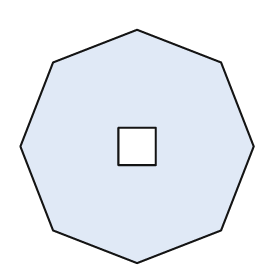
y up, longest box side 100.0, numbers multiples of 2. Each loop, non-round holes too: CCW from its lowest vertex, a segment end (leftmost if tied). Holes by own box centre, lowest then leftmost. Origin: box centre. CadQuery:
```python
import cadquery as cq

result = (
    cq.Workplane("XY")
    .moveTo(0.0, -50.0)
    .lineTo(36.0, -36.0)
    .lineTo(50.0, 0.0)
    .lineTo(36.0, 36.0)
    .lineTo(0.0, 50.0)
    .lineTo(-36.0, 36.0)
    .lineTo(-50.0, 0.0)
    .lineTo(-36.0, -36.0)
    .close()
    .moveTo(-8.0, -8.0)
    .lineTo(8.0, -8.0)
    .lineTo(8.0, 8.0)
    .lineTo(-8.0, 8.0)
    .close()
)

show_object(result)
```